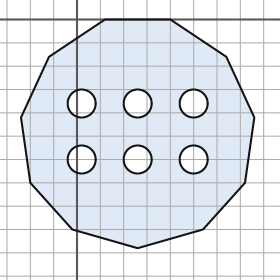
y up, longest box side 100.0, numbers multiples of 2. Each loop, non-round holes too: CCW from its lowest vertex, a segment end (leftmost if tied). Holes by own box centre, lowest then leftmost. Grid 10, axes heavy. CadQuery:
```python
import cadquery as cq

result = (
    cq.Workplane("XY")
    .moveTo(26.0, -98.0)
    .lineTo(54.0, -90.0)
    .lineTo(72.0, -70.0)
    .lineTo(76.0, -42.0)
    .lineTo(64.0, -16.0)
    .lineTo(40.0, 0.0)
    .lineTo(12.0, 0.0)
    .lineTo(-12.0, -16.0)
    .lineTo(-24.0, -42.0)
    .lineTo(-20.0, -70.0)
    .lineTo(-2.0, -90.0)
    .close()
    .moveTo(2.0, -60.0)
    .circle(6.0)
    .moveTo(26.0, -60.0)
    .circle(6.0)
    .moveTo(50.0, -60.0)
    .circle(6.0)
    .moveTo(2.0, -36.0)
    .circle(6.0)
    .moveTo(26.0, -36.0)
    .circle(6.0)
    .moveTo(50.0, -36.0)
    .circle(6.0)
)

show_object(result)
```